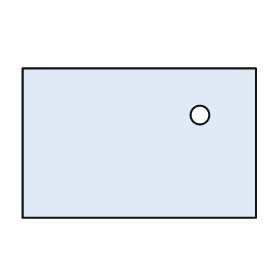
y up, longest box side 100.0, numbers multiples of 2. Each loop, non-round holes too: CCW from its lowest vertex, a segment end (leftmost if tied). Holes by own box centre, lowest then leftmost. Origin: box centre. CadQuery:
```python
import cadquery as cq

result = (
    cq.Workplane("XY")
    .moveTo(-50.0, -32.0)
    .lineTo(50.0, -32.0)
    .lineTo(50.0, 32.0)
    .lineTo(-50.0, 32.0)
    .close()
    .moveTo(26.0, 12.0)
    .circle(4.0)
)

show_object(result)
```